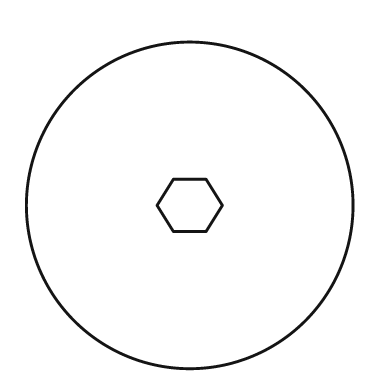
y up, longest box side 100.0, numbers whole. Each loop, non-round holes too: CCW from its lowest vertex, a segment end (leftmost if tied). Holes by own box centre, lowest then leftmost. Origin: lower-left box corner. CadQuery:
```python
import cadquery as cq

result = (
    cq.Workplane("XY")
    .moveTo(50.0, 50.0)
    .circle(50.0)
    .moveTo(45.0, 42.0)
    .lineTo(55.0, 42.0)
    .lineTo(60.0, 50.0)
    .lineTo(55.0, 58.0)
    .lineTo(45.0, 58.0)
    .lineTo(40.0, 50.0)
    .close()
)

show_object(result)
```